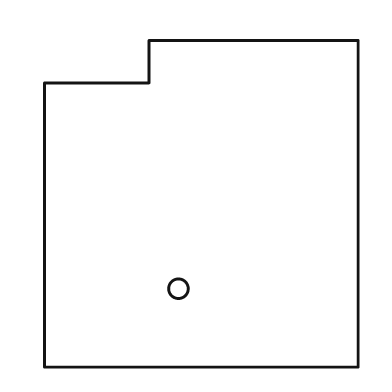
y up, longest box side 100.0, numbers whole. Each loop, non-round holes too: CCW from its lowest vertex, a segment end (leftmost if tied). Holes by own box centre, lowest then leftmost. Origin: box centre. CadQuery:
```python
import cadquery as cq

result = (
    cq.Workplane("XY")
    .moveTo(-48.0, -50.0)
    .lineTo(48.0, -50.0)
    .lineTo(48.0, 50.0)
    .lineTo(-16.0, 50.0)
    .lineTo(-16.0, 37.0)
    .lineTo(-48.0, 37.0)
    .close()
    .moveTo(-7.0, -26.0)
    .circle(3.0)
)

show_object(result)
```